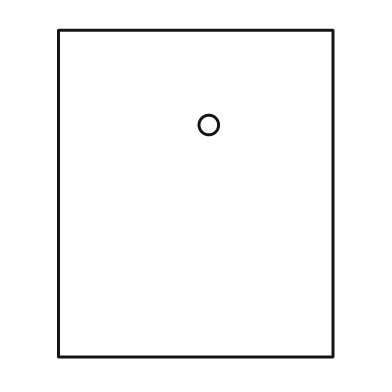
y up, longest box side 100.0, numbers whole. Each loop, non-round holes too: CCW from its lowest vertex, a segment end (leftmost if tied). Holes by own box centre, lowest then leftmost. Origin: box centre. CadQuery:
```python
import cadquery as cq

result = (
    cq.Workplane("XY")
    .moveTo(-42.0, -50.0)
    .lineTo(42.0, -50.0)
    .lineTo(42.0, 50.0)
    .lineTo(-42.0, 50.0)
    .close()
    .moveTo(4.0, 21.0)
    .circle(3.0)
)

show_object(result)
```